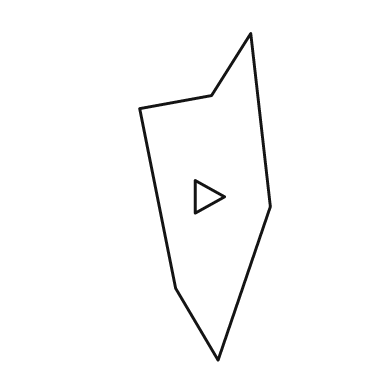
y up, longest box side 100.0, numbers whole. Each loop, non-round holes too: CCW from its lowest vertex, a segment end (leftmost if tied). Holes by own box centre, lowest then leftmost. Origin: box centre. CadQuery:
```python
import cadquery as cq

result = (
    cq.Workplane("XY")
    .moveTo(4.0, -50.0)
    .lineTo(20.0, -3.0)
    .lineTo(14.0, 50.0)
    .lineTo(2.0, 31.0)
    .lineTo(-20.0, 27.0)
    .lineTo(-9.0, -28.0)
    .close()
    .moveTo(-3.0, -5.0)
    .lineTo(6.0, 0.0)
    .lineTo(-3.0, 5.0)
    .close()
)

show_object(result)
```